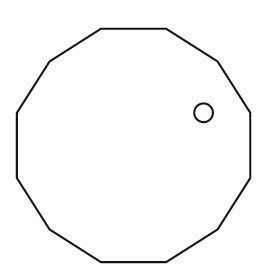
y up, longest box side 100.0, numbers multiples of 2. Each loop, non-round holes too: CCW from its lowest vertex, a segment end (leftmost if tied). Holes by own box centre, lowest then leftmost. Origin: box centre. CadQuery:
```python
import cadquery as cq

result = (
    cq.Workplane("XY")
    .moveTo(-14.0, -50.0)
    .lineTo(14.0, -50.0)
    .lineTo(36.0, -36.0)
    .lineTo(50.0, -14.0)
    .lineTo(50.0, 14.0)
    .lineTo(36.0, 36.0)
    .lineTo(14.0, 50.0)
    .lineTo(-14.0, 50.0)
    .lineTo(-36.0, 36.0)
    .lineTo(-50.0, 14.0)
    .lineTo(-50.0, -14.0)
    .lineTo(-36.0, -36.0)
    .close()
    .moveTo(30.0, 14.0)
    .circle(4.0)
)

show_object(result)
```